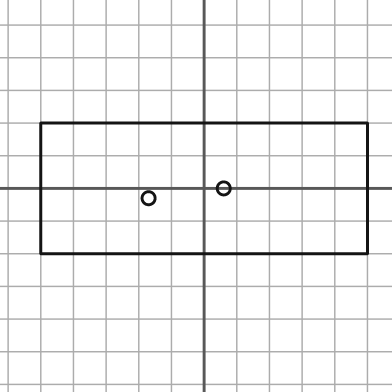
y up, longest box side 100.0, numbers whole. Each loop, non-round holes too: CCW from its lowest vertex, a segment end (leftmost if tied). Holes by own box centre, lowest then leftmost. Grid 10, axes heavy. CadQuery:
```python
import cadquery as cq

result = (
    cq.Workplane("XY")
    .moveTo(-50.0, -20.0)
    .lineTo(50.0, -20.0)
    .lineTo(50.0, 20.0)
    .lineTo(-50.0, 20.0)
    .close()
    .moveTo(-17.0, -3.0)
    .circle(2.0)
    .moveTo(6.0, 0.0)
    .circle(2.0)
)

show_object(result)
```